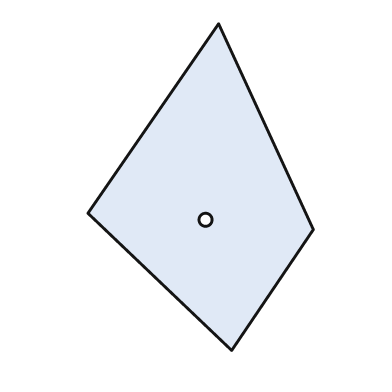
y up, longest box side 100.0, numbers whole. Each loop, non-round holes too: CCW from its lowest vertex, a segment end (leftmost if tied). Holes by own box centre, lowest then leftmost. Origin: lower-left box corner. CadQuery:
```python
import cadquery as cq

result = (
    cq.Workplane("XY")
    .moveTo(44.0, 0.0)
    .lineTo(69.0, 37.0)
    .lineTo(40.0, 100.0)
    .lineTo(0.0, 42.0)
    .close()
    .moveTo(36.0, 40.0)
    .circle(2.0)
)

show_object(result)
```